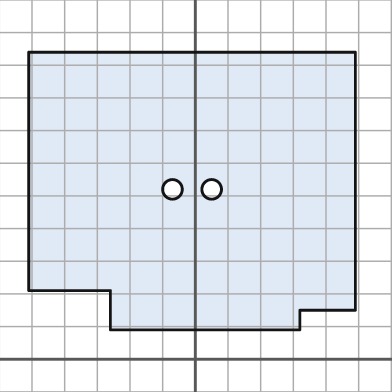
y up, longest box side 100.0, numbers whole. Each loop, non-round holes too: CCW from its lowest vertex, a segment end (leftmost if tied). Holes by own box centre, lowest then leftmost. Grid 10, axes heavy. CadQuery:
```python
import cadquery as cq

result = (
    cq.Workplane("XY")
    .moveTo(-26.0, 9.0)
    .lineTo(32.0, 9.0)
    .lineTo(32.0, 15.0)
    .lineTo(49.0, 15.0)
    .lineTo(49.0, 94.0)
    .lineTo(-51.0, 94.0)
    .lineTo(-51.0, 21.0)
    .lineTo(-26.0, 21.0)
    .close()
    .moveTo(-7.0, 52.0)
    .circle(3.0)
    .moveTo(5.0, 52.0)
    .circle(3.0)
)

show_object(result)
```